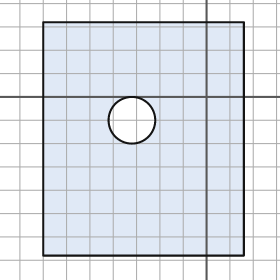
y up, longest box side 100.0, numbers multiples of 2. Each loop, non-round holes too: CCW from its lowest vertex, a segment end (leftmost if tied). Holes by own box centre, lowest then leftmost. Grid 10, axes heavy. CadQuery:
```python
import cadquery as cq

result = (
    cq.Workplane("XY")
    .moveTo(-70.0, -68.0)
    .lineTo(16.0, -68.0)
    .lineTo(16.0, 32.0)
    .lineTo(-70.0, 32.0)
    .close()
    .moveTo(-32.0, -10.0)
    .circle(10.0)
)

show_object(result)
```